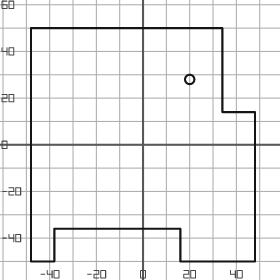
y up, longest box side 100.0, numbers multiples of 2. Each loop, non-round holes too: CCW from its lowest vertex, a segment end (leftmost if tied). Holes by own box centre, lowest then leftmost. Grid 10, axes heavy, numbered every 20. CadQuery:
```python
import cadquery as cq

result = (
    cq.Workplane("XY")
    .moveTo(-48.0, -50.0)
    .lineTo(-38.0, -50.0)
    .lineTo(-38.0, -36.0)
    .lineTo(16.0, -36.0)
    .lineTo(16.0, -50.0)
    .lineTo(48.0, -50.0)
    .lineTo(48.0, 14.0)
    .lineTo(34.0, 14.0)
    .lineTo(34.0, 50.0)
    .lineTo(-48.0, 50.0)
    .close()
    .moveTo(20.0, 28.0)
    .circle(2.0)
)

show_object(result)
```